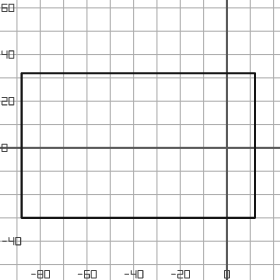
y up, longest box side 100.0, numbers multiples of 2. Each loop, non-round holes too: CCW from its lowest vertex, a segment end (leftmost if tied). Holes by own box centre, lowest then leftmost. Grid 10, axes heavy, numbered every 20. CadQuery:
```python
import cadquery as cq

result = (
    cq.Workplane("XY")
    .moveTo(-88.0, -30.0)
    .lineTo(12.0, -30.0)
    .lineTo(12.0, 32.0)
    .lineTo(-88.0, 32.0)
    .close()
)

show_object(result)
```